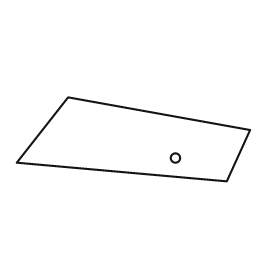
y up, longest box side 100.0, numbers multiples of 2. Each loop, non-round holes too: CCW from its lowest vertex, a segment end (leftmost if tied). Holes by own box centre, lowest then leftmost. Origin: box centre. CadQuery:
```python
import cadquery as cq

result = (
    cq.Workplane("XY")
    .moveTo(40.0, -18.0)
    .lineTo(50.0, 4.0)
    .lineTo(-28.0, 18.0)
    .lineTo(-50.0, -10.0)
    .close()
    .moveTo(18.0, -8.0)
    .circle(2.0)
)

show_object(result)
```